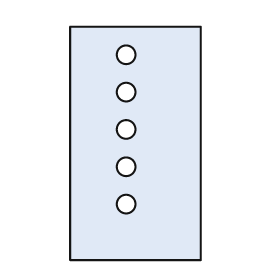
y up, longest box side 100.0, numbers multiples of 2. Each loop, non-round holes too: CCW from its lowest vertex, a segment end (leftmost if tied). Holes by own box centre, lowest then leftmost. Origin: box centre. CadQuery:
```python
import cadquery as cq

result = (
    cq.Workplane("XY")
    .moveTo(-28.0, -50.0)
    .lineTo(28.0, -50.0)
    .lineTo(28.0, 50.0)
    .lineTo(-28.0, 50.0)
    .close()
    .moveTo(-4.0, -26.0)
    .circle(4.0)
    .moveTo(-4.0, -10.0)
    .circle(4.0)
    .moveTo(-4.0, 6.0)
    .circle(4.0)
    .moveTo(-4.0, 22.0)
    .circle(4.0)
    .moveTo(-4.0, 38.0)
    .circle(4.0)
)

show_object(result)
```